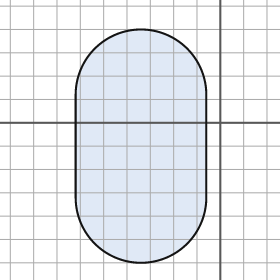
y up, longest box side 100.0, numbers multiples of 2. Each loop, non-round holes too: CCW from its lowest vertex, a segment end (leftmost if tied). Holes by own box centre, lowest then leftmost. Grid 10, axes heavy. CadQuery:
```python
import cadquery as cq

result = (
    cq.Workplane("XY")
    .moveTo(-62.0, -32.0)
    .threePointArc((-34.0, -60.0), (-6.0, -32.0))
    .lineTo(-6.0, 12.0)
    .threePointArc((-34.0, 40.0), (-62.0, 12.0))
    .close()
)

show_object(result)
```